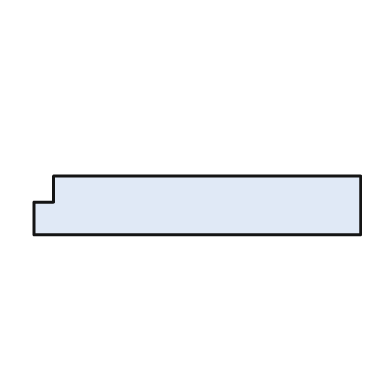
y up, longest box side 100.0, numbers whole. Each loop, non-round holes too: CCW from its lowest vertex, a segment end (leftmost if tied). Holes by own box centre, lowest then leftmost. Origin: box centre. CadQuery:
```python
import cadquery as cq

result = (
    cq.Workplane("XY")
    .moveTo(-50.0, -9.0)
    .lineTo(50.0, -9.0)
    .lineTo(50.0, 9.0)
    .lineTo(-44.0, 9.0)
    .lineTo(-44.0, 1.0)
    .lineTo(-50.0, 1.0)
    .close()
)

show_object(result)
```